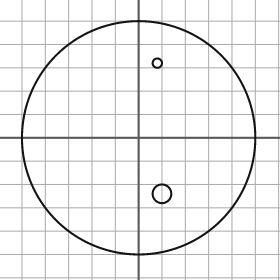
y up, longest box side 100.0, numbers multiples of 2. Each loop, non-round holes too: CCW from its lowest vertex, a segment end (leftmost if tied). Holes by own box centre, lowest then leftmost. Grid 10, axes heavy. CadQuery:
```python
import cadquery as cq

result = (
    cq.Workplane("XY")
    .moveTo(0.0, 0.0)
    .circle(50.0)
    .moveTo(10.0, -24.0)
    .circle(4.0)
    .moveTo(8.0, 32.0)
    .circle(2.0)
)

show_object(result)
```